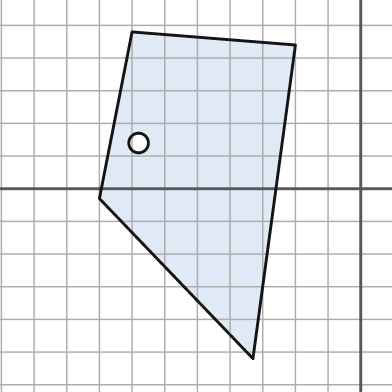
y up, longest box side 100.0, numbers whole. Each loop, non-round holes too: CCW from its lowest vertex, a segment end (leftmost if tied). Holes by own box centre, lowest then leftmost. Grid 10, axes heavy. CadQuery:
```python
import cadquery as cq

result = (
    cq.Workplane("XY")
    .moveTo(-33.0, -52.0)
    .lineTo(-20.0, 44.0)
    .lineTo(-70.0, 48.0)
    .lineTo(-80.0, -3.0)
    .close()
    .moveTo(-68.0, 14.0)
    .circle(3.0)
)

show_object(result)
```